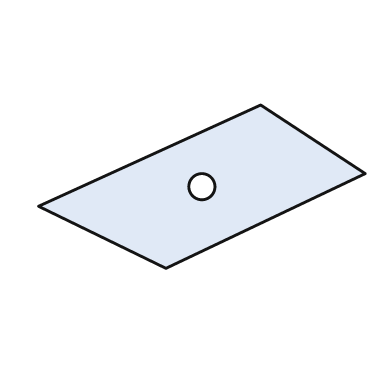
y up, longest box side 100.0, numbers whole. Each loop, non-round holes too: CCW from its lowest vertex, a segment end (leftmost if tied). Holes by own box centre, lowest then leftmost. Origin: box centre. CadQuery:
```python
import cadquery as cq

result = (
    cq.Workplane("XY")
    .moveTo(-11.0, -25.0)
    .lineTo(50.0, 4.0)
    .lineTo(18.0, 25.0)
    .lineTo(-50.0, -6.0)
    .close()
    .moveTo(0.0, 0.0)
    .circle(4.0)
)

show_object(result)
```